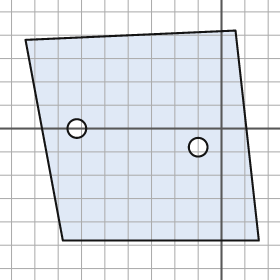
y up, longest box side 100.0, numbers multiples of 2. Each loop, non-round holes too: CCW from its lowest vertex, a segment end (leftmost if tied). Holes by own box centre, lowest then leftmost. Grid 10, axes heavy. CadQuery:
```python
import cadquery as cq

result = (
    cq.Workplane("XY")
    .moveTo(-68.0, -48.0)
    .lineTo(16.0, -48.0)
    .lineTo(6.0, 42.0)
    .lineTo(-84.0, 38.0)
    .close()
    .moveTo(-10.0, -8.0)
    .circle(4.0)
    .moveTo(-62.0, 0.0)
    .circle(4.0)
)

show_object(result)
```